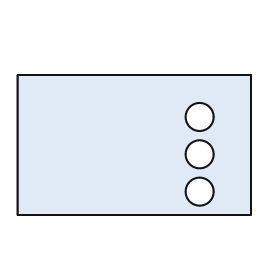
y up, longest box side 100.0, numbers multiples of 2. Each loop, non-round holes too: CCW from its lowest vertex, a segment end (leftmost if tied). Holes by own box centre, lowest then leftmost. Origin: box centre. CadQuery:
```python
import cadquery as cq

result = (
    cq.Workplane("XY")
    .moveTo(-50.0, -30.0)
    .lineTo(50.0, -30.0)
    .lineTo(50.0, 30.0)
    .lineTo(-50.0, 30.0)
    .close()
    .moveTo(28.0, -20.0)
    .circle(6.0)
    .moveTo(28.0, -4.0)
    .circle(6.0)
    .moveTo(28.0, 12.0)
    .circle(6.0)
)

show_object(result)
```